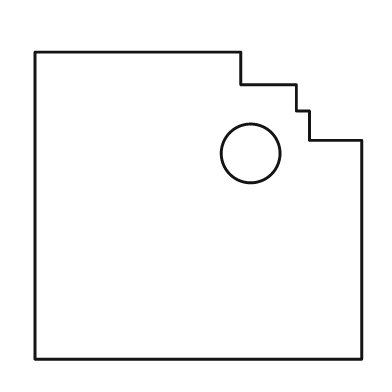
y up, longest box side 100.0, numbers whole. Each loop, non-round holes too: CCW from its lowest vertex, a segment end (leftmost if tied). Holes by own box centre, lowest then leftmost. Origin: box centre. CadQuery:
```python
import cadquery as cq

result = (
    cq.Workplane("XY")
    .moveTo(-50.0, -47.0)
    .lineTo(50.0, -47.0)
    .lineTo(50.0, 20.0)
    .lineTo(34.0, 20.0)
    .lineTo(34.0, 29.0)
    .lineTo(30.0, 29.0)
    .lineTo(30.0, 37.0)
    .lineTo(13.0, 37.0)
    .lineTo(13.0, 47.0)
    .lineTo(-50.0, 47.0)
    .close()
    .moveTo(16.0, 16.0)
    .circle(9.0)
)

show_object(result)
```